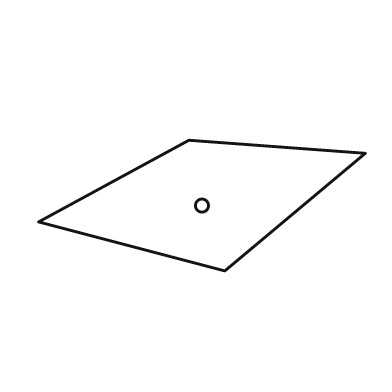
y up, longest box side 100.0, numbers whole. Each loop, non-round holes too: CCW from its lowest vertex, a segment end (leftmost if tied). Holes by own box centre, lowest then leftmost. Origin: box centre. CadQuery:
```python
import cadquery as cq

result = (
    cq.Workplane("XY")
    .moveTo(7.0, -20.0)
    .lineTo(50.0, 16.0)
    .lineTo(-4.0, 20.0)
    .lineTo(-50.0, -5.0)
    .close()
    .moveTo(0.0, 0.0)
    .circle(2.0)
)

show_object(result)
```